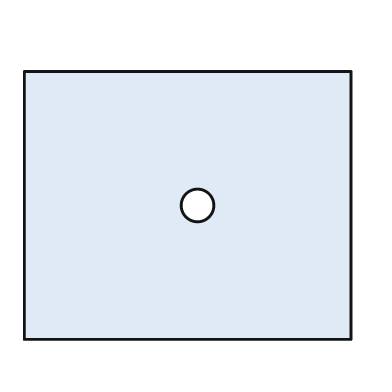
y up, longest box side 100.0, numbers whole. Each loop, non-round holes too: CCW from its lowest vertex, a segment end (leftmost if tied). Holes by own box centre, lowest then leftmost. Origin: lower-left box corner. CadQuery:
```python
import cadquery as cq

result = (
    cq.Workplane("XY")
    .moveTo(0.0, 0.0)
    .lineTo(100.0, 0.0)
    .lineTo(100.0, 82.0)
    .lineTo(0.0, 82.0)
    .close()
    .moveTo(53.0, 41.0)
    .circle(5.0)
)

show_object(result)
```